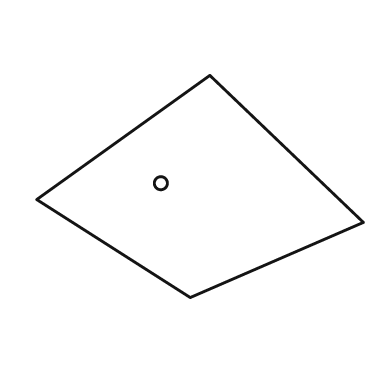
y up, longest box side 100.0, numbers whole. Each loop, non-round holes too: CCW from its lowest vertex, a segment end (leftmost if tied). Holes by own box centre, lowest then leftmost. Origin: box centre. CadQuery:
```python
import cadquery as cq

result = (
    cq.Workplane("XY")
    .moveTo(-3.0, -34.0)
    .lineTo(50.0, -11.0)
    .lineTo(3.0, 34.0)
    .lineTo(-50.0, -4.0)
    .close()
    .moveTo(-12.0, 1.0)
    .circle(2.0)
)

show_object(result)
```